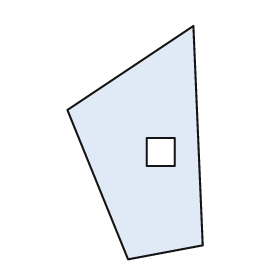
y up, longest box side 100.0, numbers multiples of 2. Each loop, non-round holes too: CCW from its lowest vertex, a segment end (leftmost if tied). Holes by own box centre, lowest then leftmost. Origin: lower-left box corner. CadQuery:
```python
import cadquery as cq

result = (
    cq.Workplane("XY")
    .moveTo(26.0, 0.0)
    .lineTo(58.0, 6.0)
    .lineTo(54.0, 100.0)
    .lineTo(0.0, 64.0)
    .close()
    .moveTo(34.0, 40.0)
    .lineTo(46.0, 40.0)
    .lineTo(46.0, 52.0)
    .lineTo(34.0, 52.0)
    .close()
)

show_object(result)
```